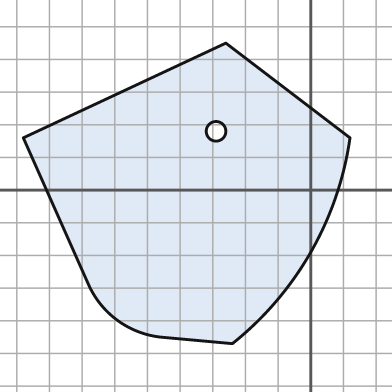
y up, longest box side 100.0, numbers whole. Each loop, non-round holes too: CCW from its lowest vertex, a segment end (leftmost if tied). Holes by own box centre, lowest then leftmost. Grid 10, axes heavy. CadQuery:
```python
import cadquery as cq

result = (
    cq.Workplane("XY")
    .moveTo(-24.0, -47.0)
    .threePointArc((0.0, -19.0), (12.0, 16.0))
    .lineTo(-26.0, 45.0)
    .lineTo(-88.0, 16.0)
    .lineTo(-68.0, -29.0)
    .threePointArc((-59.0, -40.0), (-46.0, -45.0))
    .close()
    .moveTo(-29.0, 18.0)
    .circle(3.0)
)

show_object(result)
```